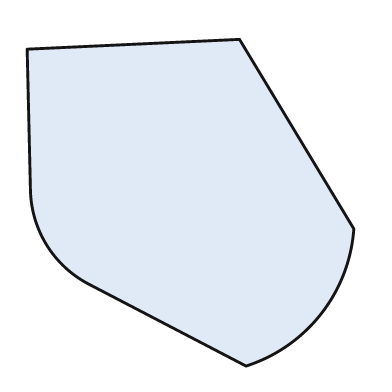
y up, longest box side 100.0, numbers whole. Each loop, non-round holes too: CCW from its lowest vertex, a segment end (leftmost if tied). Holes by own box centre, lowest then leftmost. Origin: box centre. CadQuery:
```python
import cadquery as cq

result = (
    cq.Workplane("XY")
    .moveTo(17.0, -50.0)
    .threePointArc((40.0, -34.0), (50.0, -8.0))
    .lineTo(15.0, 50.0)
    .lineTo(-50.0, 47.0)
    .lineTo(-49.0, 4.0)
    .threePointArc((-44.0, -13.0), (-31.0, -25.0))
    .close()
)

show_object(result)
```